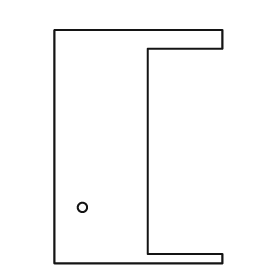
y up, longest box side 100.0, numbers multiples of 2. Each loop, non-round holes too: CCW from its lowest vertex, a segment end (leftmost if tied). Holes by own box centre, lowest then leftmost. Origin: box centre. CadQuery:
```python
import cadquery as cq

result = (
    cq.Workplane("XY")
    .moveTo(-36.0, -50.0)
    .lineTo(36.0, -50.0)
    .lineTo(36.0, -46.0)
    .lineTo(4.0, -46.0)
    .lineTo(4.0, 42.0)
    .lineTo(36.0, 42.0)
    .lineTo(36.0, 50.0)
    .lineTo(-36.0, 50.0)
    .close()
    .moveTo(-24.0, -26.0)
    .circle(2.0)
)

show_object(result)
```